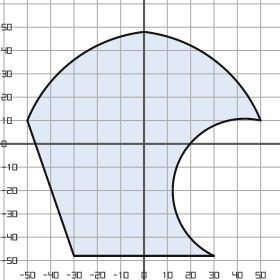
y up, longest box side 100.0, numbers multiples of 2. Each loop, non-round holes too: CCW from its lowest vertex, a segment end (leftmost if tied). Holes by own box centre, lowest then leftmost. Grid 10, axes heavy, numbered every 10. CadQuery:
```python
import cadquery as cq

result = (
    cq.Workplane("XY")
    .moveTo(-30.0, -48.0)
    .lineTo(30.0, -48.0)
    .threePointArc((14.0, -10.0), (50.0, 10.0))
    .threePointArc((30.0, 36.0), (0.0, 48.0))
    .threePointArc((-30.0, 36.0), (-50.0, 10.0))
    .close()
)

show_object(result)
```